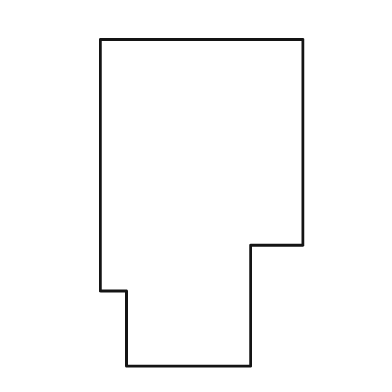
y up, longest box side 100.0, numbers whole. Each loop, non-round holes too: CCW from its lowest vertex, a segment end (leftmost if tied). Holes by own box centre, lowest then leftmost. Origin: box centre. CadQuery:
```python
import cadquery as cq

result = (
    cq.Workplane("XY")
    .moveTo(-23.0, -50.0)
    .lineTo(15.0, -50.0)
    .lineTo(15.0, -13.0)
    .lineTo(31.0, -13.0)
    .lineTo(31.0, 50.0)
    .lineTo(-31.0, 50.0)
    .lineTo(-31.0, -27.0)
    .lineTo(-23.0, -27.0)
    .close()
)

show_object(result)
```